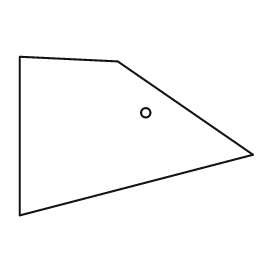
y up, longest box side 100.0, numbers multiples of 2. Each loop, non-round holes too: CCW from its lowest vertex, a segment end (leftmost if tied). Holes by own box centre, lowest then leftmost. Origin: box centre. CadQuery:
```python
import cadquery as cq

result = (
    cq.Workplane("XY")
    .moveTo(-50.0, -34.0)
    .lineTo(50.0, -8.0)
    .lineTo(-8.0, 32.0)
    .lineTo(-50.0, 34.0)
    .close()
    .moveTo(4.0, 10.0)
    .circle(2.0)
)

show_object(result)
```